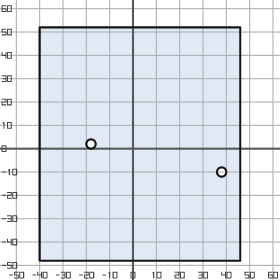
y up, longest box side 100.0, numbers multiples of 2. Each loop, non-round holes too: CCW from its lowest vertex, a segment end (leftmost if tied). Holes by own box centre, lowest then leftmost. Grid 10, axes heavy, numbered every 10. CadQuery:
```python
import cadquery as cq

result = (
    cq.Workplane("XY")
    .moveTo(-40.0, -48.0)
    .lineTo(46.0, -48.0)
    .lineTo(46.0, 52.0)
    .lineTo(-40.0, 52.0)
    .close()
    .moveTo(38.0, -10.0)
    .circle(2.0)
    .moveTo(-18.0, 2.0)
    .circle(2.0)
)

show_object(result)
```